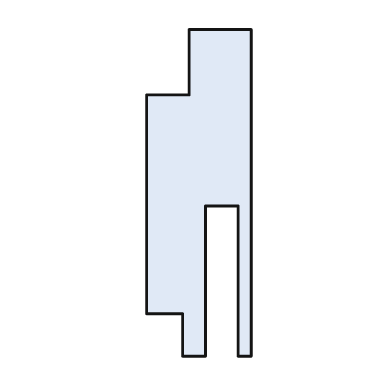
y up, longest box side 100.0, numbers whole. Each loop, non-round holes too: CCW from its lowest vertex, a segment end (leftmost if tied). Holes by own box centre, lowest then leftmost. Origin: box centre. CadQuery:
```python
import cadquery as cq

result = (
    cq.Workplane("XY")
    .moveTo(-5.0, -50.0)
    .lineTo(2.0, -50.0)
    .lineTo(2.0, -4.0)
    .lineTo(12.0, -4.0)
    .lineTo(12.0, -50.0)
    .lineTo(16.0, -50.0)
    .lineTo(16.0, 50.0)
    .lineTo(-3.0, 50.0)
    .lineTo(-3.0, 30.0)
    .lineTo(-16.0, 30.0)
    .lineTo(-16.0, -37.0)
    .lineTo(-5.0, -37.0)
    .close()
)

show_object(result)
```